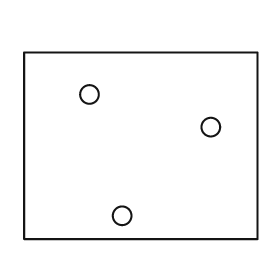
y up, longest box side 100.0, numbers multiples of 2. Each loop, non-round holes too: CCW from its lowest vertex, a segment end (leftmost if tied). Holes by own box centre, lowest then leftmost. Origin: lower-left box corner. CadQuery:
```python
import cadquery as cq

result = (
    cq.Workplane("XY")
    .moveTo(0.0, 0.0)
    .lineTo(100.0, 0.0)
    .lineTo(100.0, 80.0)
    .lineTo(0.0, 80.0)
    .close()
    .moveTo(42.0, 10.0)
    .circle(4.0)
    .moveTo(80.0, 48.0)
    .circle(4.0)
    .moveTo(28.0, 62.0)
    .circle(4.0)
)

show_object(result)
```